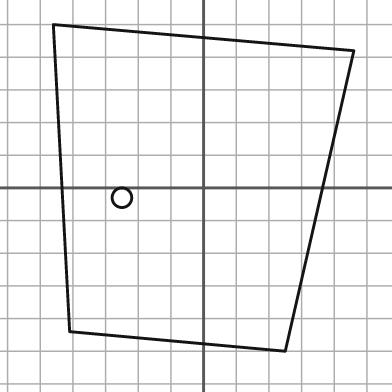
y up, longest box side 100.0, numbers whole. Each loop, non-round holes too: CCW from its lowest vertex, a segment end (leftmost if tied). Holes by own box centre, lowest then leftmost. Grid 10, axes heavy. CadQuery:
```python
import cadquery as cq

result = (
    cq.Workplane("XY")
    .moveTo(25.0, -50.0)
    .lineTo(46.0, 42.0)
    .lineTo(-46.0, 50.0)
    .lineTo(-41.0, -44.0)
    .close()
    .moveTo(-25.0, -3.0)
    .circle(3.0)
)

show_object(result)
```